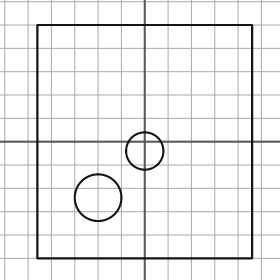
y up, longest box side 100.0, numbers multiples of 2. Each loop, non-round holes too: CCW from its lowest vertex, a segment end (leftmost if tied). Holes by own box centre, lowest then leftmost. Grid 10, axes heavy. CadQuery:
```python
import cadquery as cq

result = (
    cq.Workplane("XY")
    .moveTo(-46.0, -50.0)
    .lineTo(46.0, -50.0)
    .lineTo(46.0, 50.0)
    .lineTo(-46.0, 50.0)
    .close()
    .moveTo(-20.0, -24.0)
    .circle(10.0)
    .moveTo(0.0, -4.0)
    .circle(8.0)
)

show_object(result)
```